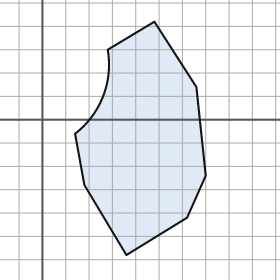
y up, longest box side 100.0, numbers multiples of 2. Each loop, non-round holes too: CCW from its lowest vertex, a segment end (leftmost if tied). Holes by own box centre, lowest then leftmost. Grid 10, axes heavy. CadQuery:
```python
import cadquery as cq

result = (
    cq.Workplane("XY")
    .moveTo(36.0, -58.0)
    .lineTo(62.0, -42.0)
    .lineTo(70.0, -24.0)
    .lineTo(66.0, 14.0)
    .lineTo(48.0, 42.0)
    .lineTo(28.0, 30.0)
    .threePointArc((26.0, 10.0), (14.0, -6.0))
    .lineTo(18.0, -28.0)
    .close()
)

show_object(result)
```